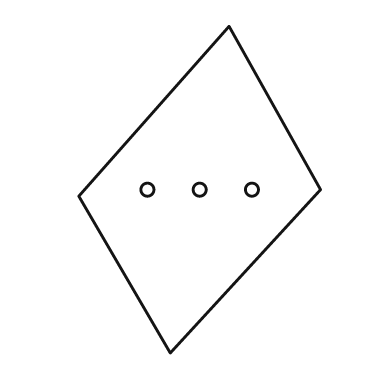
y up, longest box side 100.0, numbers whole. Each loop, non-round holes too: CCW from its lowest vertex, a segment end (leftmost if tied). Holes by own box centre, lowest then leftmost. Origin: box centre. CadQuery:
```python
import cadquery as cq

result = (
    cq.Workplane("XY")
    .moveTo(-9.0, -50.0)
    .lineTo(37.0, 0.0)
    .lineTo(9.0, 50.0)
    .lineTo(-37.0, -2.0)
    .close()
    .moveTo(-16.0, 0.0)
    .circle(2.0)
    .moveTo(0.0, 0.0)
    .circle(2.0)
    .moveTo(16.0, 0.0)
    .circle(2.0)
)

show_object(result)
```